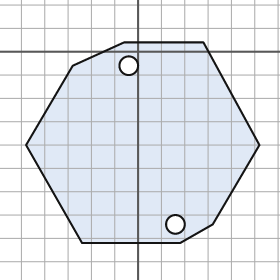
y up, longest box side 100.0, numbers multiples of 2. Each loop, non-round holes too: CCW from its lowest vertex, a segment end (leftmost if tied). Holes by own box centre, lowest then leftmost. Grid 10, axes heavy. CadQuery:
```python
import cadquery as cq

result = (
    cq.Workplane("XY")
    .moveTo(-24.0, -82.0)
    .lineTo(18.0, -82.0)
    .lineTo(32.0, -74.0)
    .lineTo(52.0, -40.0)
    .lineTo(28.0, 4.0)
    .lineTo(-6.0, 4.0)
    .lineTo(-28.0, -6.0)
    .lineTo(-48.0, -40.0)
    .close()
    .moveTo(16.0, -74.0)
    .circle(4.0)
    .moveTo(-4.0, -6.0)
    .circle(4.0)
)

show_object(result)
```